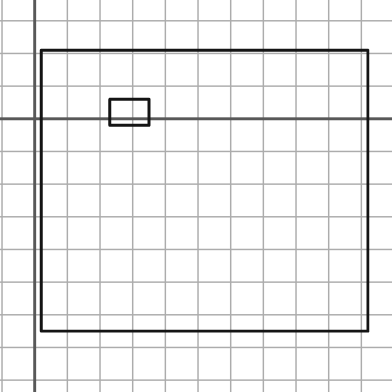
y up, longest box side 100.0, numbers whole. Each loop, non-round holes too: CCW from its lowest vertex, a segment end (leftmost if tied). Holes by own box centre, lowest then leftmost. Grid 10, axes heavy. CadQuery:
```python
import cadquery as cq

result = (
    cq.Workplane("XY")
    .moveTo(2.0, -65.0)
    .lineTo(102.0, -65.0)
    .lineTo(102.0, 21.0)
    .lineTo(2.0, 21.0)
    .close()
    .moveTo(23.0, -2.0)
    .lineTo(35.0, -2.0)
    .lineTo(35.0, 6.0)
    .lineTo(23.0, 6.0)
    .close()
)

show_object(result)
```